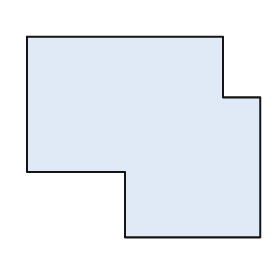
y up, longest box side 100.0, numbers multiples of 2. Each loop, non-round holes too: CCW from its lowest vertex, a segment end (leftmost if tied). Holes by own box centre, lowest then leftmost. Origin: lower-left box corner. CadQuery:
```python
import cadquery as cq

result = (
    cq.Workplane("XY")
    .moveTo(42.0, 0.0)
    .lineTo(100.0, 0.0)
    .lineTo(100.0, 60.0)
    .lineTo(84.0, 60.0)
    .lineTo(84.0, 86.0)
    .lineTo(0.0, 86.0)
    .lineTo(0.0, 28.0)
    .lineTo(42.0, 28.0)
    .close()
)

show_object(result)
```